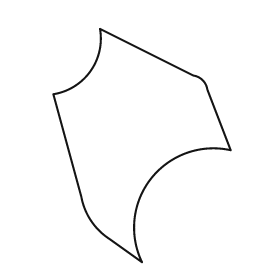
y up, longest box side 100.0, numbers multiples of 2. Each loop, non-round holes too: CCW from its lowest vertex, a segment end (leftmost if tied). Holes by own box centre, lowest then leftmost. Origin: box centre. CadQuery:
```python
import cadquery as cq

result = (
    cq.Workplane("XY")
    .moveTo(0.0, -50.0)
    .threePointArc((4.0, -14.0), (38.0, -2.0))
    .lineTo(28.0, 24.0)
    .threePointArc((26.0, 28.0), (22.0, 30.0))
    .lineTo(-18.0, 50.0)
    .threePointArc((-22.0, 32.0), (-38.0, 22.0))
    .lineTo(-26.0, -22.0)
    .threePointArc((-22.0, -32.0), (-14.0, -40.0))
    .close()
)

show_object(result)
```